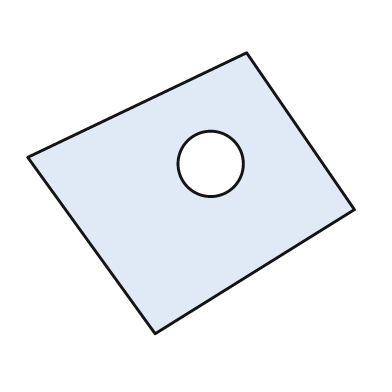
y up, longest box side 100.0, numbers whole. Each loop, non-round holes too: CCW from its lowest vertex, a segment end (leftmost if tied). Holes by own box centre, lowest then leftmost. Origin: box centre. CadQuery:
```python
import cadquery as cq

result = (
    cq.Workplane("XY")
    .moveTo(-11.0, -43.0)
    .lineTo(50.0, -5.0)
    .lineTo(17.0, 43.0)
    .lineTo(-50.0, 11.0)
    .close()
    .moveTo(6.0, 9.0)
    .circle(10.0)
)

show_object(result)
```